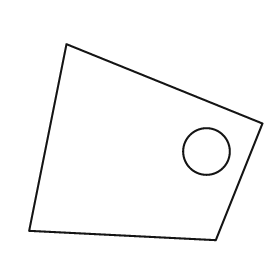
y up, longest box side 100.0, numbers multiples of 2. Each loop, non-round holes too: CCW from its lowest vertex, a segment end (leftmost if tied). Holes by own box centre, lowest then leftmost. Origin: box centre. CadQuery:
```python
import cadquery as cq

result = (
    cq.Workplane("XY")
    .moveTo(30.0, -42.0)
    .lineTo(50.0, 8.0)
    .lineTo(-34.0, 42.0)
    .lineTo(-50.0, -38.0)
    .close()
    .moveTo(26.0, -4.0)
    .circle(10.0)
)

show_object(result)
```